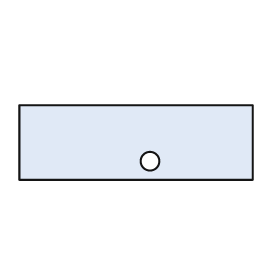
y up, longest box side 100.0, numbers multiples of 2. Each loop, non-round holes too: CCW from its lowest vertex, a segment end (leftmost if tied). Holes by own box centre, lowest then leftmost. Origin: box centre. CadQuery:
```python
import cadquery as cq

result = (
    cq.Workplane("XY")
    .moveTo(-50.0, -16.0)
    .lineTo(50.0, -16.0)
    .lineTo(50.0, 16.0)
    .lineTo(-50.0, 16.0)
    .close()
    .moveTo(6.0, -8.0)
    .circle(4.0)
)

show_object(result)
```